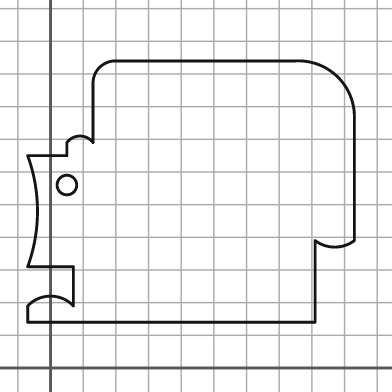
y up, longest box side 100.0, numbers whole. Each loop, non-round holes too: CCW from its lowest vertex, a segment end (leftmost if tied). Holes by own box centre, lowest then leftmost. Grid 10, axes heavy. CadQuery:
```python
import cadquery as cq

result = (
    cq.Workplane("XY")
    .moveTo(-7.0, 14.0)
    .lineTo(81.0, 14.0)
    .lineTo(81.0, 39.0)
    .threePointArc((87.0, 37.0), (93.0, 39.0))
    .lineTo(93.0, 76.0)
    .threePointArc((88.0, 89.0), (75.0, 94.0))
    .lineTo(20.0, 94.0)
    .threePointArc((15.0, 92.0), (13.0, 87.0))
    .lineTo(13.0, 69.0)
    .threePointArc((9.0, 71.0), (5.0, 69.0))
    .lineTo(5.0, 65.0)
    .lineTo(-7.0, 65.0)
    .threePointArc((-4.0, 48.0), (-7.0, 31.0))
    .lineTo(7.0, 31.0)
    .lineTo(7.0, 19.0)
    .threePointArc((0.0, 22.0), (-7.0, 19.0))
    .close()
    .moveTo(5.0, 56.0)
    .circle(3.0)
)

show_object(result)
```